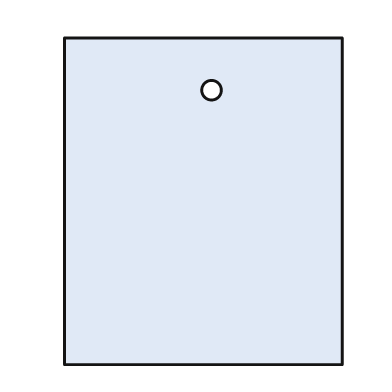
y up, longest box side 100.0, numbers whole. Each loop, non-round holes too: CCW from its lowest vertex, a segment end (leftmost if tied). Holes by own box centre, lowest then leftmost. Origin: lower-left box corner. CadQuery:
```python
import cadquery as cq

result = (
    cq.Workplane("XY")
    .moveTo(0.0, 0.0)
    .lineTo(85.0, 0.0)
    .lineTo(85.0, 100.0)
    .lineTo(0.0, 100.0)
    .close()
    .moveTo(45.0, 84.0)
    .circle(3.0)
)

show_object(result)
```